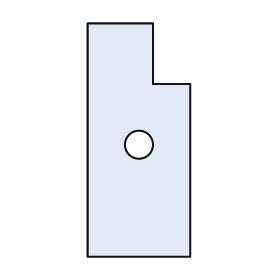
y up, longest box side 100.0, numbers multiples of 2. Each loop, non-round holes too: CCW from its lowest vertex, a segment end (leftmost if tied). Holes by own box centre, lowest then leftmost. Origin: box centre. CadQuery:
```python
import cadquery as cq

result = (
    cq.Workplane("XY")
    .moveTo(-22.0, -50.0)
    .lineTo(22.0, -50.0)
    .lineTo(22.0, 24.0)
    .lineTo(6.0, 24.0)
    .lineTo(6.0, 50.0)
    .lineTo(-22.0, 50.0)
    .close()
    .moveTo(0.0, -2.0)
    .circle(6.0)
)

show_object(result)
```